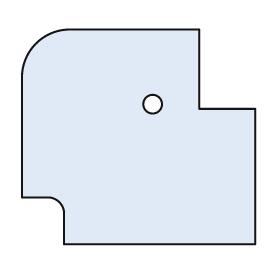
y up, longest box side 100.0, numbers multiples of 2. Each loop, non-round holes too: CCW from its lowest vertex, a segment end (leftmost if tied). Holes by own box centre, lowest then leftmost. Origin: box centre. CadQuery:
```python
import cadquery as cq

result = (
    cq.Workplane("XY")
    .moveTo(-32.0, -46.0)
    .lineTo(50.0, -46.0)
    .lineTo(50.0, 12.0)
    .lineTo(26.0, 12.0)
    .lineTo(26.0, 46.0)
    .lineTo(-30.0, 46.0)
    .threePointArc((-44.0, 40.0), (-50.0, 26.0))
    .lineTo(-50.0, -26.0)
    .lineTo(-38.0, -26.0)
    .threePointArc((-34.0, -28.0), (-32.0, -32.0))
    .close()
    .moveTo(6.0, 14.0)
    .circle(4.0)
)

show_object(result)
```